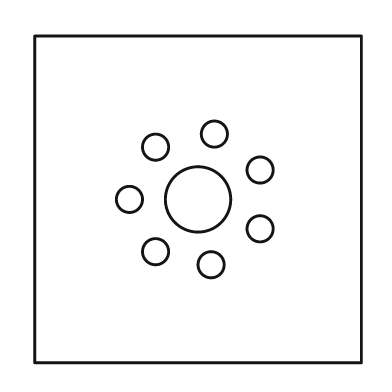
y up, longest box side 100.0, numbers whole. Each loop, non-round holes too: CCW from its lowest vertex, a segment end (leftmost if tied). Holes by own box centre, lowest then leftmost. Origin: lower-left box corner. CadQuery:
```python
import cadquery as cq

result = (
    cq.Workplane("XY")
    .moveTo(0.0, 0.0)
    .lineTo(100.0, 0.0)
    .lineTo(100.0, 100.0)
    .lineTo(0.0, 100.0)
    .close()
    .moveTo(54.0, 30.0)
    .circle(4.0)
    .moveTo(37.0, 34.0)
    .circle(4.0)
    .moveTo(69.0, 41.0)
    .circle(4.0)
    .moveTo(29.0, 50.0)
    .circle(4.0)
    .moveTo(50.0, 50.0)
    .circle(10.0)
    .moveTo(69.0, 59.0)
    .circle(4.0)
    .moveTo(37.0, 66.0)
    .circle(4.0)
    .moveTo(55.0, 70.0)
    .circle(4.0)
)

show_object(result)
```